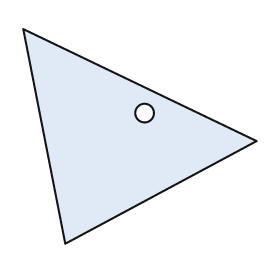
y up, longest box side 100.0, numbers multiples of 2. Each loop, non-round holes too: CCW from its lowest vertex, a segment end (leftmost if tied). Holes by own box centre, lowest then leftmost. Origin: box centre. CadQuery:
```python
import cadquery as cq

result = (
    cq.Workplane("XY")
    .moveTo(-32.0, -46.0)
    .lineTo(50.0, -2.0)
    .lineTo(-50.0, 46.0)
    .close()
    .moveTo(2.0, 10.0)
    .circle(4.0)
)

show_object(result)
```